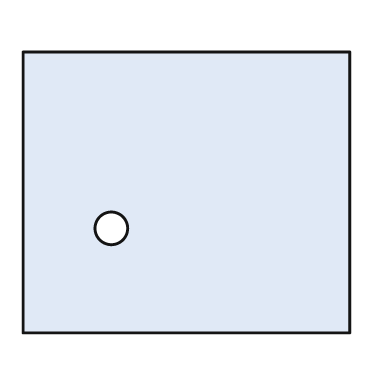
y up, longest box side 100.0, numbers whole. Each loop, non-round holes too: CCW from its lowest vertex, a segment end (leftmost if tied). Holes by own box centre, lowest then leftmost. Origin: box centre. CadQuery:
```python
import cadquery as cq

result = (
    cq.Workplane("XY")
    .moveTo(-50.0, -43.0)
    .lineTo(50.0, -43.0)
    .lineTo(50.0, 43.0)
    .lineTo(-50.0, 43.0)
    .close()
    .moveTo(-23.0, -11.0)
    .circle(5.0)
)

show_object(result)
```